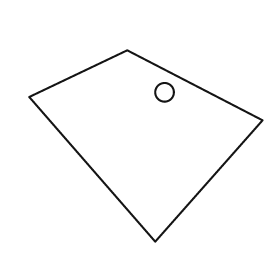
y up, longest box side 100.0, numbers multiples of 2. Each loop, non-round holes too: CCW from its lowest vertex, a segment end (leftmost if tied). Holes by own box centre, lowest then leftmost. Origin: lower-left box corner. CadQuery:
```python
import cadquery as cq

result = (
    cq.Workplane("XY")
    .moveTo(54.0, 0.0)
    .lineTo(100.0, 52.0)
    .lineTo(42.0, 82.0)
    .lineTo(0.0, 62.0)
    .close()
    .moveTo(58.0, 64.0)
    .circle(4.0)
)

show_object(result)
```